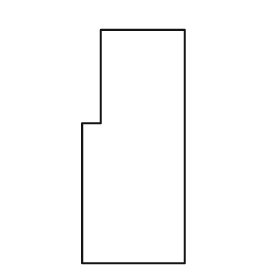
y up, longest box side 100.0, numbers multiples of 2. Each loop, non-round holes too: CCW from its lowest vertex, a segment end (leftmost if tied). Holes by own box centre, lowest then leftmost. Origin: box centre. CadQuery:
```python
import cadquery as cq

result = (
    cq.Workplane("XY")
    .moveTo(-22.0, -50.0)
    .lineTo(22.0, -50.0)
    .lineTo(22.0, 50.0)
    .lineTo(-14.0, 50.0)
    .lineTo(-14.0, 10.0)
    .lineTo(-22.0, 10.0)
    .close()
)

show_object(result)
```